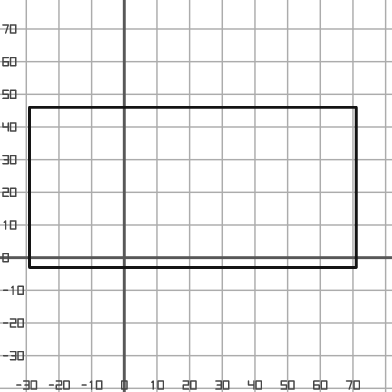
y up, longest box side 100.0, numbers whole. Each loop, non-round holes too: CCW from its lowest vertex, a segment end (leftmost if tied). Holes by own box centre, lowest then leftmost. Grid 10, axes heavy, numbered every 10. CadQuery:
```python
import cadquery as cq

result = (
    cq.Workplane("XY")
    .moveTo(-29.0, -3.0)
    .lineTo(71.0, -3.0)
    .lineTo(71.0, 46.0)
    .lineTo(-29.0, 46.0)
    .close()
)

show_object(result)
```